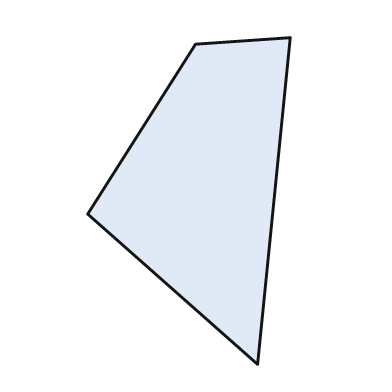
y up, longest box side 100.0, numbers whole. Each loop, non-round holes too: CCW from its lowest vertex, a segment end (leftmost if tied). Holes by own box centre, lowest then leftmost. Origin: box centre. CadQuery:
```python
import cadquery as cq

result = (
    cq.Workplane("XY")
    .moveTo(21.0, -50.0)
    .lineTo(31.0, 50.0)
    .lineTo(2.0, 48.0)
    .lineTo(-31.0, -4.0)
    .close()
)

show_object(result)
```